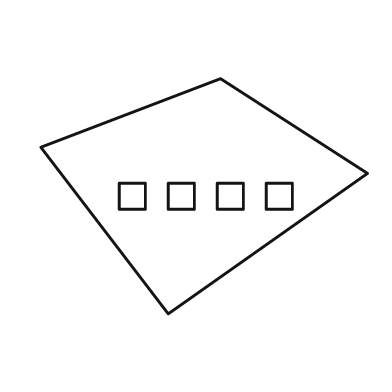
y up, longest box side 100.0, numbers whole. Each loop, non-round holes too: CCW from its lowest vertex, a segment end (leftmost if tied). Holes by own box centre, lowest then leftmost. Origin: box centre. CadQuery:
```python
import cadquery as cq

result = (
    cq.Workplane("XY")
    .moveTo(-11.0, -36.0)
    .lineTo(50.0, 7.0)
    .lineTo(5.0, 36.0)
    .lineTo(-50.0, 15.0)
    .close()
    .moveTo(-26.0, -4.0)
    .lineTo(-18.0, -4.0)
    .lineTo(-18.0, 4.0)
    .lineTo(-26.0, 4.0)
    .close()
    .moveTo(-11.0, -4.0)
    .lineTo(-3.0, -4.0)
    .lineTo(-3.0, 4.0)
    .lineTo(-11.0, 4.0)
    .close()
    .moveTo(4.0, -4.0)
    .lineTo(12.0, -4.0)
    .lineTo(12.0, 4.0)
    .lineTo(4.0, 4.0)
    .close()
    .moveTo(19.0, -4.0)
    .lineTo(27.0, -4.0)
    .lineTo(27.0, 4.0)
    .lineTo(19.0, 4.0)
    .close()
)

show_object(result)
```